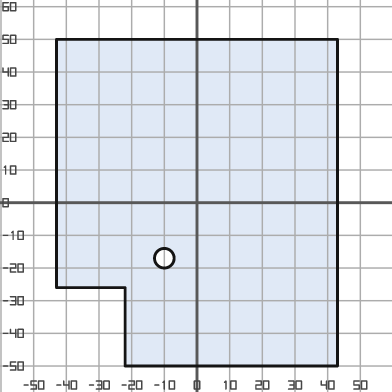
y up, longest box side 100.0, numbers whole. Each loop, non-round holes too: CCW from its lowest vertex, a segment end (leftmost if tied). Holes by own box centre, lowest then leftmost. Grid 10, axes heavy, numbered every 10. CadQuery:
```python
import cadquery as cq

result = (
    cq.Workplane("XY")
    .moveTo(-22.0, -50.0)
    .lineTo(43.0, -50.0)
    .lineTo(43.0, 50.0)
    .lineTo(-43.0, 50.0)
    .lineTo(-43.0, -26.0)
    .lineTo(-22.0, -26.0)
    .close()
    .moveTo(-10.0, -17.0)
    .circle(3.0)
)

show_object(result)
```